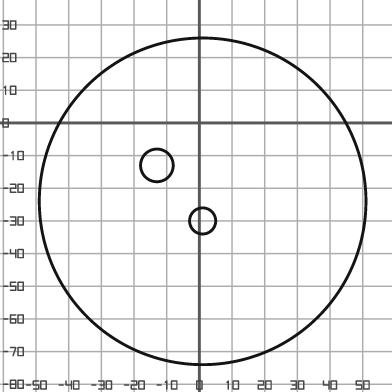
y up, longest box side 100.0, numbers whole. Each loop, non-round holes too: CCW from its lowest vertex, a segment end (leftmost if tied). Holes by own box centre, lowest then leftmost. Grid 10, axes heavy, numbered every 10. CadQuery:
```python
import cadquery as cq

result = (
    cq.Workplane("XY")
    .moveTo(1.0, -24.0)
    .circle(50.0)
    .moveTo(1.0, -30.0)
    .circle(4.0)
    .moveTo(-13.0, -13.0)
    .circle(5.0)
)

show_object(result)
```